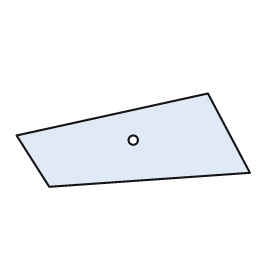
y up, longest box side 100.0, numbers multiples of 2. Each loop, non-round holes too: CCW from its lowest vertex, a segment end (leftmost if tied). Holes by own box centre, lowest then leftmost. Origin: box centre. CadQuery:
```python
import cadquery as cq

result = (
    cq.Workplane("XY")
    .moveTo(-36.0, -20.0)
    .lineTo(50.0, -14.0)
    .lineTo(32.0, 20.0)
    .lineTo(-50.0, 2.0)
    .close()
    .moveTo(0.0, 0.0)
    .circle(2.0)
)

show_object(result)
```